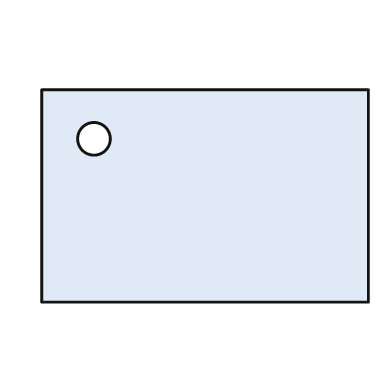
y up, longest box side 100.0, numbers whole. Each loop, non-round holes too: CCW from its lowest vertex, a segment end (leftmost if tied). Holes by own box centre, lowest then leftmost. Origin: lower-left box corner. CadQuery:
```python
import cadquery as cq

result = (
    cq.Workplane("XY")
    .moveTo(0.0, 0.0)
    .lineTo(100.0, 0.0)
    .lineTo(100.0, 65.0)
    .lineTo(0.0, 65.0)
    .close()
    .moveTo(16.0, 50.0)
    .circle(5.0)
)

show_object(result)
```